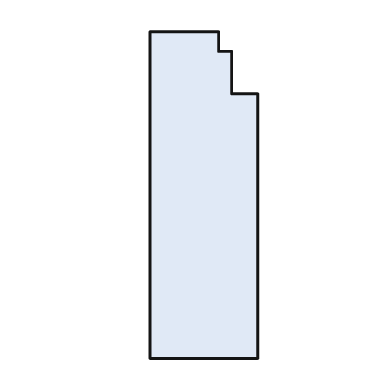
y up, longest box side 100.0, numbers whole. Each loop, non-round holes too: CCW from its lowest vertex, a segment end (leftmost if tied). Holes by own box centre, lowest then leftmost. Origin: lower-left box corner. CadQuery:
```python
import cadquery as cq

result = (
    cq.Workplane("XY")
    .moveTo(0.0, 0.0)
    .lineTo(33.0, 0.0)
    .lineTo(33.0, 81.0)
    .lineTo(25.0, 81.0)
    .lineTo(25.0, 94.0)
    .lineTo(21.0, 94.0)
    .lineTo(21.0, 100.0)
    .lineTo(0.0, 100.0)
    .close()
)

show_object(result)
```